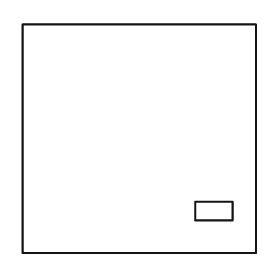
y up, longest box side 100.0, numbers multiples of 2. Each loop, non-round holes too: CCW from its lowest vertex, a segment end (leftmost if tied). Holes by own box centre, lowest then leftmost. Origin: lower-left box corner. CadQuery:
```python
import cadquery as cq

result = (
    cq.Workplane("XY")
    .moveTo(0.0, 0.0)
    .lineTo(100.0, 0.0)
    .lineTo(100.0, 98.0)
    .lineTo(0.0, 98.0)
    .close()
    .moveTo(74.0, 14.0)
    .lineTo(90.0, 14.0)
    .lineTo(90.0, 22.0)
    .lineTo(74.0, 22.0)
    .close()
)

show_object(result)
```